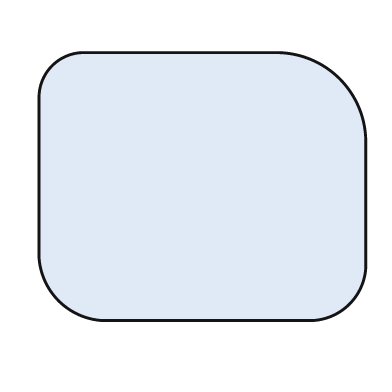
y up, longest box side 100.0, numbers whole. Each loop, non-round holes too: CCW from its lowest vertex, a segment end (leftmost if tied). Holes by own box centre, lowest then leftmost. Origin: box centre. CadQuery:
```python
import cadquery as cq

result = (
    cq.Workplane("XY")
    .moveTo(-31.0, -41.0)
    .lineTo(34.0, -41.0)
    .threePointArc((45.0, -36.0), (50.0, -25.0))
    .lineTo(50.0, 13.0)
    .threePointArc((42.0, 33.0), (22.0, 41.0))
    .lineTo(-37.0, 41.0)
    .threePointArc((-46.0, 37.0), (-50.0, 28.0))
    .lineTo(-50.0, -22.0)
    .threePointArc((-44.0, -35.0), (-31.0, -41.0))
    .close()
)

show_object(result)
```